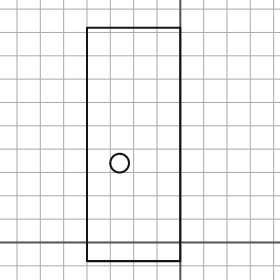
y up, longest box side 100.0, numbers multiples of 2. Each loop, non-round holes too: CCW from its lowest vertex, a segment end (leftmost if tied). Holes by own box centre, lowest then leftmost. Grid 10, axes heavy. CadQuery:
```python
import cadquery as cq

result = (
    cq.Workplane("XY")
    .moveTo(-40.0, -8.0)
    .lineTo(0.0, -8.0)
    .lineTo(0.0, 92.0)
    .lineTo(-40.0, 92.0)
    .close()
    .moveTo(-26.0, 34.0)
    .circle(4.0)
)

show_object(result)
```